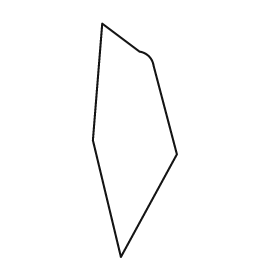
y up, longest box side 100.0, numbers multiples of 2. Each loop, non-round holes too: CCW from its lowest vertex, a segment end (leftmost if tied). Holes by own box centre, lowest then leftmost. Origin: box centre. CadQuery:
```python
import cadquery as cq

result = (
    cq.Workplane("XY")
    .moveTo(-6.0, -50.0)
    .lineTo(18.0, -6.0)
    .lineTo(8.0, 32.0)
    .threePointArc((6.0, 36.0), (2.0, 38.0))
    .lineTo(-14.0, 50.0)
    .lineTo(-18.0, 0.0)
    .close()
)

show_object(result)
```